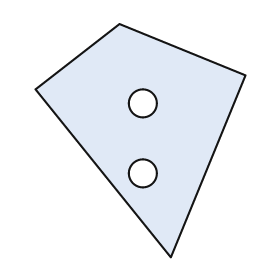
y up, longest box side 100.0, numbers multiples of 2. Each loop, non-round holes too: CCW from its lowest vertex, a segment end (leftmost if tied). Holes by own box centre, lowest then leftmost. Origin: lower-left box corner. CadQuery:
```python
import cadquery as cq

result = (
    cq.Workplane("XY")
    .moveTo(58.0, 0.0)
    .lineTo(90.0, 78.0)
    .lineTo(36.0, 100.0)
    .lineTo(0.0, 72.0)
    .close()
    .moveTo(46.0, 36.0)
    .circle(6.0)
    .moveTo(46.0, 66.0)
    .circle(6.0)
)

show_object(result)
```